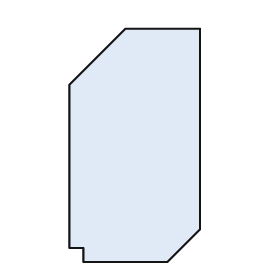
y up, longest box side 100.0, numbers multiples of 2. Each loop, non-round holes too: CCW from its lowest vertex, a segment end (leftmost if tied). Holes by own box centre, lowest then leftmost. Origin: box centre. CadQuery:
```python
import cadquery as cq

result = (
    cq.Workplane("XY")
    .moveTo(-22.0, -50.0)
    .lineTo(14.0, -50.0)
    .lineTo(28.0, -36.0)
    .lineTo(28.0, 50.0)
    .lineTo(-4.0, 50.0)
    .lineTo(-28.0, 26.0)
    .lineTo(-28.0, -44.0)
    .lineTo(-22.0, -44.0)
    .close()
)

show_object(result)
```